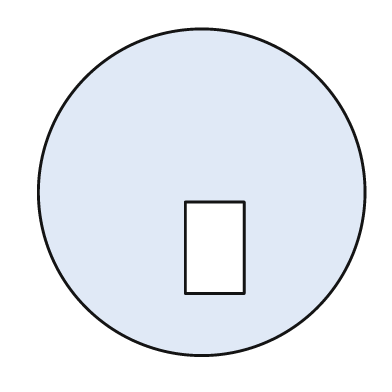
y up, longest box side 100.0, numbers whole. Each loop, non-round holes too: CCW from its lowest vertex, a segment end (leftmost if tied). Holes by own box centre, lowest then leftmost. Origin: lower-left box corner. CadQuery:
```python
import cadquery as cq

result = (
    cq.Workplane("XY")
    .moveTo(50.0, 50.0)
    .circle(50.0)
    .moveTo(45.0, 19.0)
    .lineTo(63.0, 19.0)
    .lineTo(63.0, 47.0)
    .lineTo(45.0, 47.0)
    .close()
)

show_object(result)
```